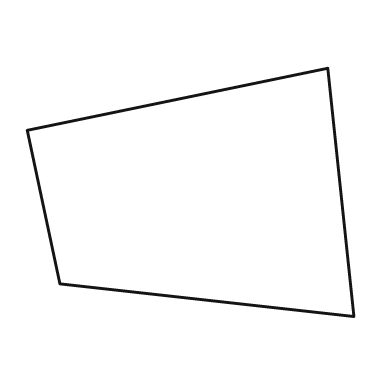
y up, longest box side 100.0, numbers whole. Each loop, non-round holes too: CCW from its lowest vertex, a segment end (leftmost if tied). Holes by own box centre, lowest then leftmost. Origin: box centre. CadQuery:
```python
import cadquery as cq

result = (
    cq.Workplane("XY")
    .moveTo(50.0, -38.0)
    .lineTo(42.0, 38.0)
    .lineTo(-50.0, 19.0)
    .lineTo(-40.0, -28.0)
    .close()
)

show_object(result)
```